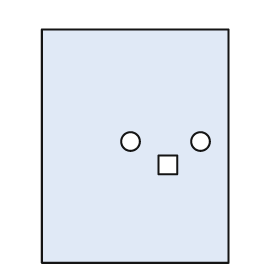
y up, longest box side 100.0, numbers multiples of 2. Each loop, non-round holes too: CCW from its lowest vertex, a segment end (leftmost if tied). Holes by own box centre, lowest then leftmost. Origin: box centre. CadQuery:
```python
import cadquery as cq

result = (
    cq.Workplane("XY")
    .moveTo(-40.0, -50.0)
    .lineTo(40.0, -50.0)
    .lineTo(40.0, 50.0)
    .lineTo(-40.0, 50.0)
    .close()
    .moveTo(10.0, -12.0)
    .lineTo(18.0, -12.0)
    .lineTo(18.0, -4.0)
    .lineTo(10.0, -4.0)
    .close()
    .moveTo(-2.0, 2.0)
    .circle(4.0)
    .moveTo(28.0, 2.0)
    .circle(4.0)
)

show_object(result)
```